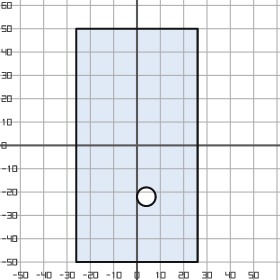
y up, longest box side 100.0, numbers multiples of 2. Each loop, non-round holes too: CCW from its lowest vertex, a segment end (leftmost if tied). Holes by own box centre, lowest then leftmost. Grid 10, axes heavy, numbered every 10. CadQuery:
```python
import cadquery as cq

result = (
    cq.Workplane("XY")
    .moveTo(-26.0, -50.0)
    .lineTo(26.0, -50.0)
    .lineTo(26.0, 50.0)
    .lineTo(-26.0, 50.0)
    .close()
    .moveTo(4.0, -22.0)
    .circle(4.0)
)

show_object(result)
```